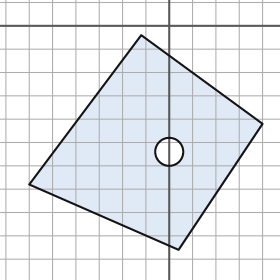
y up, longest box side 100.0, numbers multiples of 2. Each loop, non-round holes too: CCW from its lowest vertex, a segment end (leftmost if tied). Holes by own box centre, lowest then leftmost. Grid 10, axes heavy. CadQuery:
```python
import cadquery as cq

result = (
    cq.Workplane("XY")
    .moveTo(4.0, -96.0)
    .lineTo(40.0, -42.0)
    .lineTo(-12.0, -4.0)
    .lineTo(-60.0, -68.0)
    .close()
    .moveTo(0.0, -54.0)
    .circle(6.0)
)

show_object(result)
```